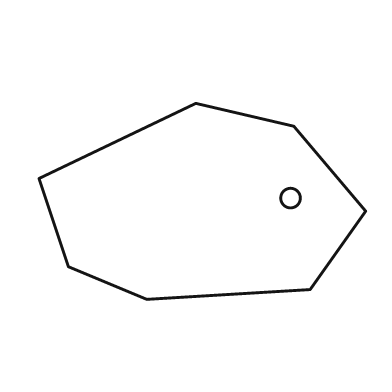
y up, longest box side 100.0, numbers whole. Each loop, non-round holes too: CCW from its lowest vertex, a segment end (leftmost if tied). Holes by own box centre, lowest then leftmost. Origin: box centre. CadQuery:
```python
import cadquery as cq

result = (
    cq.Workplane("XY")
    .moveTo(-17.0, -30.0)
    .lineTo(33.0, -27.0)
    .lineTo(50.0, -3.0)
    .lineTo(28.0, 23.0)
    .lineTo(-2.0, 30.0)
    .lineTo(-50.0, 7.0)
    .lineTo(-41.0, -20.0)
    .close()
    .moveTo(27.0, 1.0)
    .circle(3.0)
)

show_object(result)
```